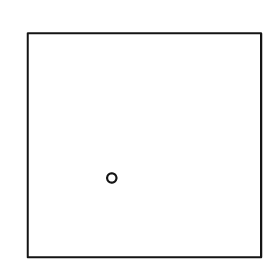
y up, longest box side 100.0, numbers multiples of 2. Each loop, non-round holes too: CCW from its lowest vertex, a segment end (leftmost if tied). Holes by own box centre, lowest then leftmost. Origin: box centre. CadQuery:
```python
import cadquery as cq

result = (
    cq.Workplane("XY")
    .moveTo(-50.0, -48.0)
    .lineTo(50.0, -48.0)
    .lineTo(50.0, 48.0)
    .lineTo(-50.0, 48.0)
    .close()
    .moveTo(-14.0, -14.0)
    .circle(2.0)
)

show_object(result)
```